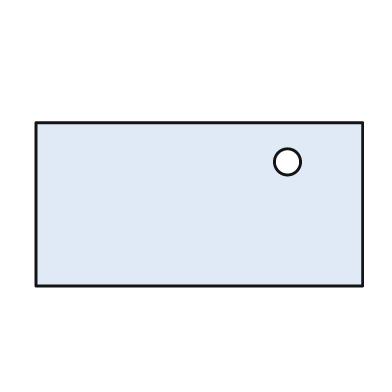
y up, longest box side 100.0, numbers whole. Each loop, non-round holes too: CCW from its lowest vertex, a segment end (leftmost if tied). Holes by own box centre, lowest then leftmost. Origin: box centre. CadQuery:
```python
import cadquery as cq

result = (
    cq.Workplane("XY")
    .moveTo(-50.0, -25.0)
    .lineTo(50.0, -25.0)
    .lineTo(50.0, 25.0)
    .lineTo(-50.0, 25.0)
    .close()
    .moveTo(27.0, 13.0)
    .circle(4.0)
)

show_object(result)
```